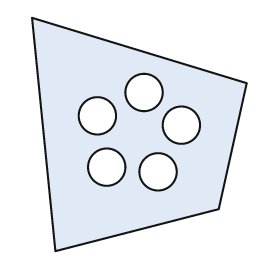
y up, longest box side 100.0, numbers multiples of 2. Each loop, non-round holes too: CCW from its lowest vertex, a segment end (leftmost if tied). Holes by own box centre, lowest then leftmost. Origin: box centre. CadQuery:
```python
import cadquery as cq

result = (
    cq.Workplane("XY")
    .moveTo(-36.0, -50.0)
    .lineTo(34.0, -32.0)
    .lineTo(46.0, 22.0)
    .lineTo(-46.0, 50.0)
    .close()
    .moveTo(8.0, -16.0)
    .circle(8.0)
    .moveTo(-14.0, -14.0)
    .circle(8.0)
    .moveTo(18.0, 4.0)
    .circle(8.0)
    .moveTo(-18.0, 8.0)
    .circle(8.0)
    .moveTo(2.0, 18.0)
    .circle(8.0)
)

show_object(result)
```